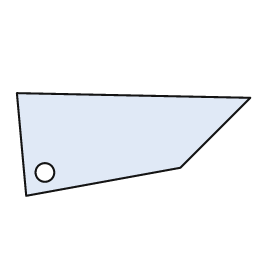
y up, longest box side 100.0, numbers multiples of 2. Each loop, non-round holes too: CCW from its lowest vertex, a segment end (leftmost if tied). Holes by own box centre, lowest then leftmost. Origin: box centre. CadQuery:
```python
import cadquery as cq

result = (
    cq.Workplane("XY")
    .moveTo(-46.0, -22.0)
    .lineTo(20.0, -10.0)
    .lineTo(50.0, 20.0)
    .lineTo(-50.0, 22.0)
    .close()
    .moveTo(-38.0, -12.0)
    .circle(4.0)
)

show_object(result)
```